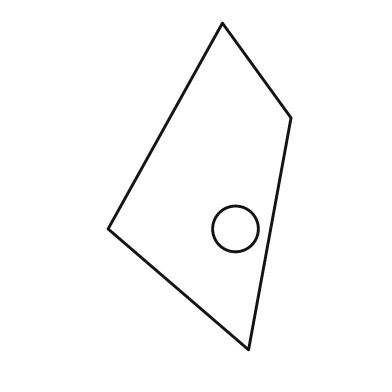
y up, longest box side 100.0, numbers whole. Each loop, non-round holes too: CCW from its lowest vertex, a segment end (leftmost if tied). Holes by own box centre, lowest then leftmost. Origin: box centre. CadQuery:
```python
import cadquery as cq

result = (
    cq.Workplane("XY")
    .moveTo(15.0, -50.0)
    .lineTo(28.0, 21.0)
    .lineTo(7.0, 50.0)
    .lineTo(-28.0, -13.0)
    .close()
    .moveTo(11.0, -13.0)
    .circle(7.0)
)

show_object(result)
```